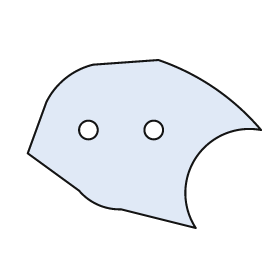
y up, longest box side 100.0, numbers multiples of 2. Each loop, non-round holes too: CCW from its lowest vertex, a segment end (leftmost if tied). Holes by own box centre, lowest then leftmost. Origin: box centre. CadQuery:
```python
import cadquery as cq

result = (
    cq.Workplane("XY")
    .moveTo(22.0, -36.0)
    .threePointArc((22.0, -6.0), (50.0, 6.0))
    .threePointArc((30.0, 24.0), (6.0, 36.0))
    .lineTo(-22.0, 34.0)
    .threePointArc((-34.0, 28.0), (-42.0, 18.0))
    .lineTo(-50.0, -4.0)
    .lineTo(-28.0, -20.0)
    .threePointArc((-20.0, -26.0), (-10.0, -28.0))
    .close()
    .moveTo(-24.0, 6.0)
    .circle(4.0)
    .moveTo(4.0, 6.0)
    .circle(4.0)
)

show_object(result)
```